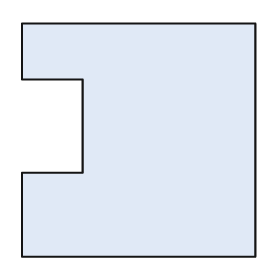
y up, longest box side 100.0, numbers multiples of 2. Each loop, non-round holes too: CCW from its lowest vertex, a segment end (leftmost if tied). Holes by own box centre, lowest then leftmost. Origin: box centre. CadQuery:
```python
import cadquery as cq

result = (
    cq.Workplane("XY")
    .moveTo(-50.0, -50.0)
    .lineTo(50.0, -50.0)
    .lineTo(50.0, 50.0)
    .lineTo(-50.0, 50.0)
    .lineTo(-50.0, 26.0)
    .lineTo(-24.0, 26.0)
    .lineTo(-24.0, -14.0)
    .lineTo(-50.0, -14.0)
    .close()
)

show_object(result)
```